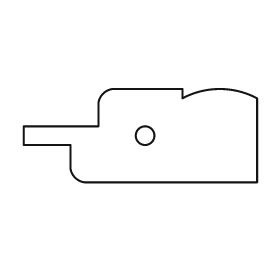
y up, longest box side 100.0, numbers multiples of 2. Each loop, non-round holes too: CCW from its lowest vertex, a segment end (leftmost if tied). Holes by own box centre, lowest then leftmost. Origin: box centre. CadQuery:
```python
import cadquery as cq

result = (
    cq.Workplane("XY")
    .moveTo(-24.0, -20.0)
    .lineTo(50.0, -20.0)
    .lineTo(50.0, 16.0)
    .threePointArc((34.0, 20.0), (18.0, 16.0))
    .lineTo(18.0, 20.0)
    .lineTo(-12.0, 20.0)
    .threePointArc((-16.0, 18.0), (-18.0, 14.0))
    .lineTo(-18.0, 4.0)
    .lineTo(-50.0, 4.0)
    .lineTo(-50.0, -4.0)
    .lineTo(-30.0, -4.0)
    .lineTo(-30.0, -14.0)
    .threePointArc((-28.0, -18.0), (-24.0, -20.0))
    .close()
    .moveTo(2.0, 0.0)
    .circle(4.0)
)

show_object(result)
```